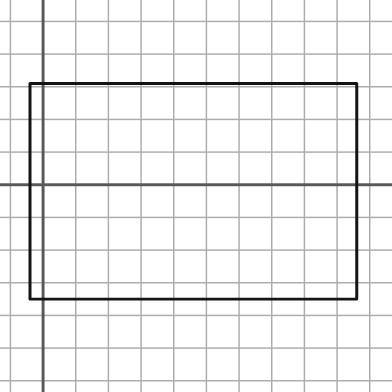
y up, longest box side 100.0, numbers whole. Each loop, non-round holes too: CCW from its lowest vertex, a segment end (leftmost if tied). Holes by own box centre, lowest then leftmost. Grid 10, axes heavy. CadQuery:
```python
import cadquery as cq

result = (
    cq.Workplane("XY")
    .moveTo(-4.0, -35.0)
    .lineTo(96.0, -35.0)
    .lineTo(96.0, 31.0)
    .lineTo(-4.0, 31.0)
    .close()
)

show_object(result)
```